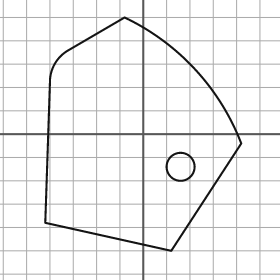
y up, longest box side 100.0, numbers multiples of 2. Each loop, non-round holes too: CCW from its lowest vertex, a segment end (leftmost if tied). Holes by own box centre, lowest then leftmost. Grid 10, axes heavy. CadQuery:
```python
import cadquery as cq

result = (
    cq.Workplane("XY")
    .moveTo(12.0, -50.0)
    .lineTo(42.0, -4.0)
    .threePointArc((22.0, 28.0), (-8.0, 50.0))
    .lineTo(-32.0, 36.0)
    .threePointArc((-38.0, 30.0), (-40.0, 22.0))
    .lineTo(-42.0, -38.0)
    .close()
    .moveTo(16.0, -14.0)
    .circle(6.0)
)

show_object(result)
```